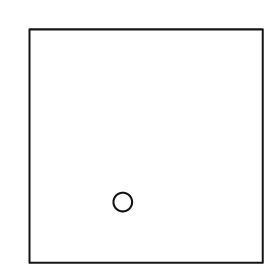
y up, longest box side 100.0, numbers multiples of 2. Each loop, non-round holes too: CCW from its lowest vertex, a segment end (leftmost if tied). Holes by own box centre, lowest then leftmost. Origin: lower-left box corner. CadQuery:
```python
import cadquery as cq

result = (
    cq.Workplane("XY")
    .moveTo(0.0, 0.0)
    .lineTo(100.0, 0.0)
    .lineTo(100.0, 100.0)
    .lineTo(0.0, 100.0)
    .close()
    .moveTo(40.0, 26.0)
    .circle(4.0)
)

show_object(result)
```